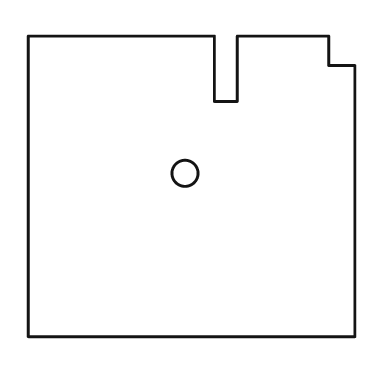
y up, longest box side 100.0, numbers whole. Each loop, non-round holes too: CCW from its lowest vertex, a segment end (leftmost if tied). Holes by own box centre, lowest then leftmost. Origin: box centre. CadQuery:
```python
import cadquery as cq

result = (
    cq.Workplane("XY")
    .moveTo(-50.0, -46.0)
    .lineTo(50.0, -46.0)
    .lineTo(50.0, 37.0)
    .lineTo(42.0, 37.0)
    .lineTo(42.0, 46.0)
    .lineTo(14.0, 46.0)
    .lineTo(14.0, 26.0)
    .lineTo(7.0, 26.0)
    .lineTo(7.0, 46.0)
    .lineTo(-50.0, 46.0)
    .close()
    .moveTo(-2.0, 4.0)
    .circle(4.0)
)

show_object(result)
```